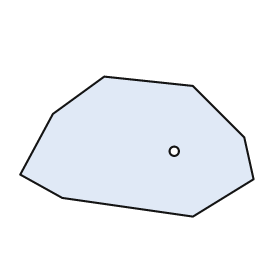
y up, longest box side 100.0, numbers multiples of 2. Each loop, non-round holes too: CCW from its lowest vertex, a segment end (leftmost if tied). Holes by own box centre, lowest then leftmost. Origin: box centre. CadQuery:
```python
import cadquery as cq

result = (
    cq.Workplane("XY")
    .moveTo(24.0, -30.0)
    .lineTo(50.0, -14.0)
    .lineTo(46.0, 4.0)
    .lineTo(24.0, 26.0)
    .lineTo(-14.0, 30.0)
    .lineTo(-36.0, 14.0)
    .lineTo(-50.0, -12.0)
    .lineTo(-32.0, -22.0)
    .close()
    .moveTo(16.0, -2.0)
    .circle(2.0)
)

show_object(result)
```